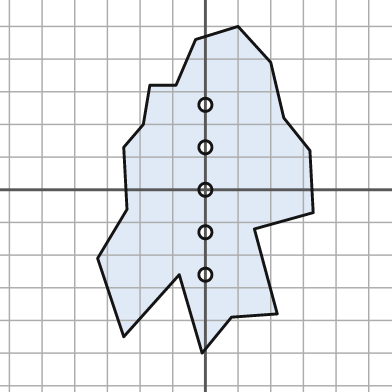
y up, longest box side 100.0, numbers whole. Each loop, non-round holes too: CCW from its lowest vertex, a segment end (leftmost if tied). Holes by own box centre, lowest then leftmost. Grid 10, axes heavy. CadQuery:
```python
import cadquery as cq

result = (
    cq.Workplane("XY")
    .moveTo(-1.0, -50.0)
    .lineTo(8.0, -39.0)
    .lineTo(22.0, -38.0)
    .lineTo(15.0, -12.0)
    .lineTo(33.0, -7.0)
    .lineTo(32.0, 12.0)
    .lineTo(24.0, 22.0)
    .lineTo(20.0, 39.0)
    .lineTo(10.0, 50.0)
    .lineTo(-3.0, 46.0)
    .lineTo(-9.0, 32.0)
    .lineTo(-17.0, 32.0)
    .lineTo(-19.0, 20.0)
    .lineTo(-25.0, 13.0)
    .lineTo(-24.0, -6.0)
    .lineTo(-33.0, -21.0)
    .lineTo(-25.0, -45.0)
    .lineTo(-8.0, -26.0)
    .close()
    .moveTo(0.0, -26.0)
    .circle(2.0)
    .moveTo(0.0, -13.0)
    .circle(2.0)
    .moveTo(0.0, 0.0)
    .circle(2.0)
    .moveTo(0.0, 13.0)
    .circle(2.0)
    .moveTo(0.0, 26.0)
    .circle(2.0)
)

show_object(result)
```